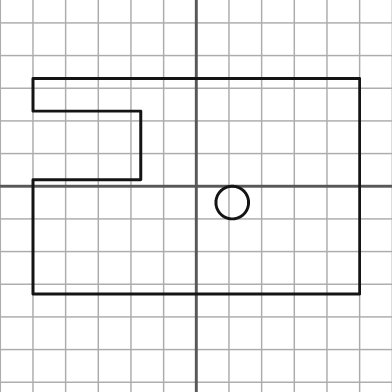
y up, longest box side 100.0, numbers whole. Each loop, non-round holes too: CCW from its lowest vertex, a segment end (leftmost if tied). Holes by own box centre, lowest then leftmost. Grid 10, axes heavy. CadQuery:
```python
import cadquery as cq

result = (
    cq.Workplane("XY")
    .moveTo(-50.0, -33.0)
    .lineTo(50.0, -33.0)
    .lineTo(50.0, 33.0)
    .lineTo(-50.0, 33.0)
    .lineTo(-50.0, 23.0)
    .lineTo(-17.0, 23.0)
    .lineTo(-17.0, 2.0)
    .lineTo(-50.0, 2.0)
    .close()
    .moveTo(11.0, -5.0)
    .circle(5.0)
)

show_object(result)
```